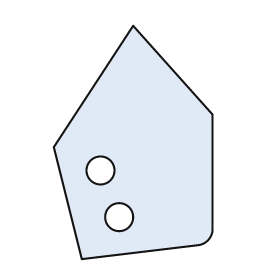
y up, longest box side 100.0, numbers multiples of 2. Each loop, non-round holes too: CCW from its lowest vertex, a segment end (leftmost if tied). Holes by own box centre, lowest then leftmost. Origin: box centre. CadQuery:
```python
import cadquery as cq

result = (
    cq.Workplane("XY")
    .moveTo(-22.0, -50.0)
    .lineTo(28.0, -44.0)
    .threePointArc((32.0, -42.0), (34.0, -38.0))
    .lineTo(34.0, 12.0)
    .lineTo(0.0, 50.0)
    .lineTo(-34.0, -2.0)
    .close()
    .moveTo(-6.0, -32.0)
    .circle(6.0)
    .moveTo(-14.0, -12.0)
    .circle(6.0)
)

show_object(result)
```